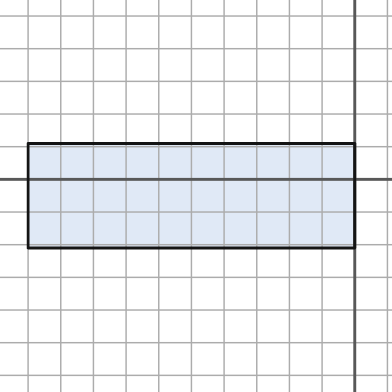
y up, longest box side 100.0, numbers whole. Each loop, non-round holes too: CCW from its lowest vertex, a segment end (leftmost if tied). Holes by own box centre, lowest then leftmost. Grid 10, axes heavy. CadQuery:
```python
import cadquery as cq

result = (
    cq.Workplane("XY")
    .moveTo(-100.0, -21.0)
    .lineTo(0.0, -21.0)
    .lineTo(0.0, 11.0)
    .lineTo(-100.0, 11.0)
    .close()
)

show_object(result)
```